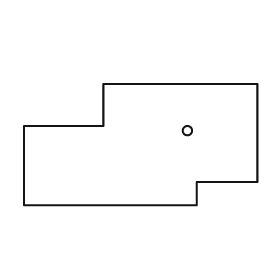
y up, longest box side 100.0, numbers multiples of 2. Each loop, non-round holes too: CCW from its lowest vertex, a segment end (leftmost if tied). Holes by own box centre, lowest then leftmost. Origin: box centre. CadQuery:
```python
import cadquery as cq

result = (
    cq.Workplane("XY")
    .moveTo(-50.0, -26.0)
    .lineTo(24.0, -26.0)
    .lineTo(24.0, -16.0)
    .lineTo(50.0, -16.0)
    .lineTo(50.0, 26.0)
    .lineTo(-16.0, 26.0)
    .lineTo(-16.0, 8.0)
    .lineTo(-50.0, 8.0)
    .close()
    .moveTo(20.0, 6.0)
    .circle(2.0)
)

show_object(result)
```